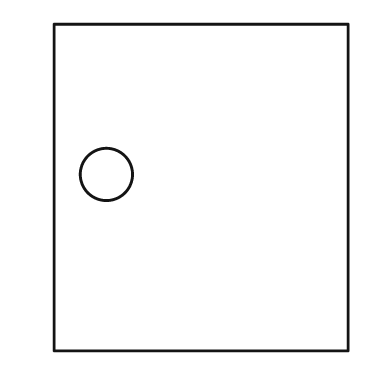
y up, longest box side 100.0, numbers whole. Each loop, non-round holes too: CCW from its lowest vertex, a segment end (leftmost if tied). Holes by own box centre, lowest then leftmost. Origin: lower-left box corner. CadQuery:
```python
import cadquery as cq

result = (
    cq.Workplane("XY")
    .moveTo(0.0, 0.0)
    .lineTo(90.0, 0.0)
    .lineTo(90.0, 100.0)
    .lineTo(0.0, 100.0)
    .close()
    .moveTo(16.0, 54.0)
    .circle(8.0)
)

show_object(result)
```